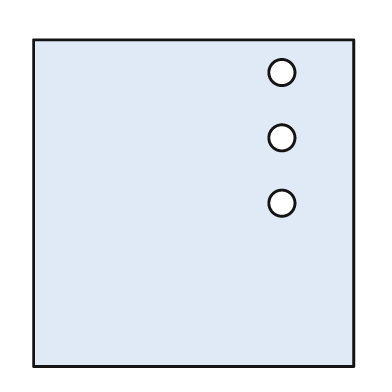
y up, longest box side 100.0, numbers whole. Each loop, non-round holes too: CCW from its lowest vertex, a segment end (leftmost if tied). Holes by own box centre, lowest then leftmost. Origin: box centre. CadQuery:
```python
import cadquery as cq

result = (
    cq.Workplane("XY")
    .moveTo(-49.0, -50.0)
    .lineTo(49.0, -50.0)
    .lineTo(49.0, 50.0)
    .lineTo(-49.0, 50.0)
    .close()
    .moveTo(27.0, 0.0)
    .circle(4.0)
    .moveTo(27.0, 20.0)
    .circle(4.0)
    .moveTo(27.0, 40.0)
    .circle(4.0)
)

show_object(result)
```